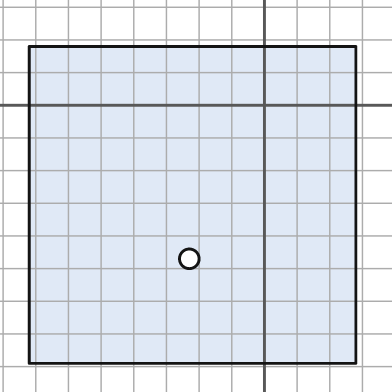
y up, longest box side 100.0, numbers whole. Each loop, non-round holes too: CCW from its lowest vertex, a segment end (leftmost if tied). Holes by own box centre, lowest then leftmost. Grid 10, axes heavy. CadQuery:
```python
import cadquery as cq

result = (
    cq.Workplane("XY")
    .moveTo(-72.0, -79.0)
    .lineTo(28.0, -79.0)
    .lineTo(28.0, 18.0)
    .lineTo(-72.0, 18.0)
    .close()
    .moveTo(-23.0, -47.0)
    .circle(3.0)
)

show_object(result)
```